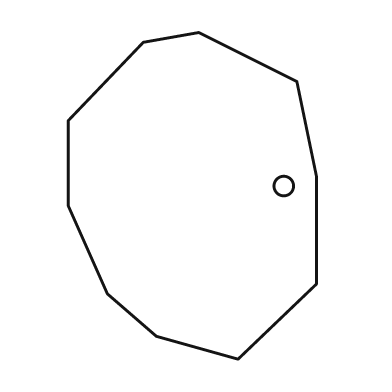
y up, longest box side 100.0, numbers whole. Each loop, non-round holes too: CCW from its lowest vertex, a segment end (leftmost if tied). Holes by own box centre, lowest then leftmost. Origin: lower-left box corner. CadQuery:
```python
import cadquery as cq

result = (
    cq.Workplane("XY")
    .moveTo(52.0, 0.0)
    .lineTo(76.0, 23.0)
    .lineTo(76.0, 56.0)
    .lineTo(70.0, 85.0)
    .lineTo(40.0, 100.0)
    .lineTo(23.0, 97.0)
    .lineTo(0.0, 73.0)
    .lineTo(0.0, 47.0)
    .lineTo(12.0, 20.0)
    .lineTo(27.0, 7.0)
    .close()
    .moveTo(66.0, 53.0)
    .circle(3.0)
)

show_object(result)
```